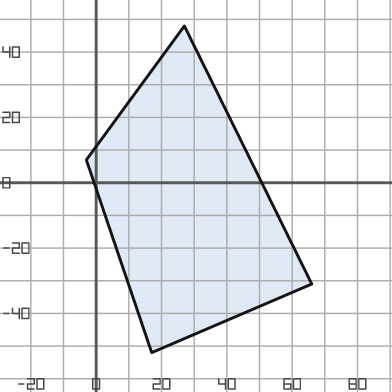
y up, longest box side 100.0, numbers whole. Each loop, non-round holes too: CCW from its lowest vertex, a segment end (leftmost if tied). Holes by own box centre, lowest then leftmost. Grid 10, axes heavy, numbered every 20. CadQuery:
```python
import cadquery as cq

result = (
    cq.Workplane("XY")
    .moveTo(17.0, -52.0)
    .lineTo(66.0, -31.0)
    .lineTo(27.0, 48.0)
    .lineTo(-3.0, 7.0)
    .close()
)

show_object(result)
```